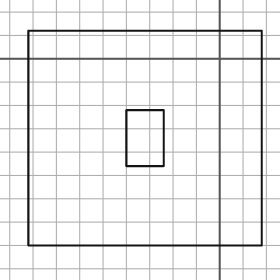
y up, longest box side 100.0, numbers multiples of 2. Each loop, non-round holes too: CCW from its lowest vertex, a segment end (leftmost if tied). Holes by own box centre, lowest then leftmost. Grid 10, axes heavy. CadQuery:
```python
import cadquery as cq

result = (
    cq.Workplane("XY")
    .moveTo(-82.0, -80.0)
    .lineTo(18.0, -80.0)
    .lineTo(18.0, 12.0)
    .lineTo(-82.0, 12.0)
    .close()
    .moveTo(-40.0, -46.0)
    .lineTo(-24.0, -46.0)
    .lineTo(-24.0, -22.0)
    .lineTo(-40.0, -22.0)
    .close()
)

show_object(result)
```